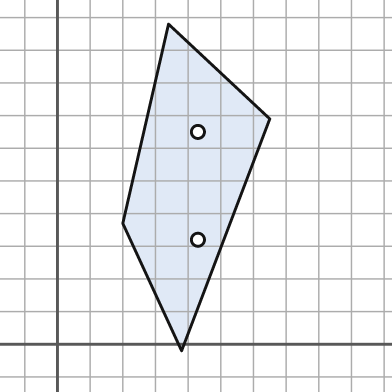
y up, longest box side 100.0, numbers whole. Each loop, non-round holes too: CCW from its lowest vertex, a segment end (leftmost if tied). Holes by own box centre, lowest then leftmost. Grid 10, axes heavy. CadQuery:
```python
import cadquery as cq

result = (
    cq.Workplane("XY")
    .moveTo(38.0, -2.0)
    .lineTo(65.0, 69.0)
    .lineTo(34.0, 98.0)
    .lineTo(20.0, 37.0)
    .close()
    .moveTo(43.0, 32.0)
    .circle(2.0)
    .moveTo(43.0, 65.0)
    .circle(2.0)
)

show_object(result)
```